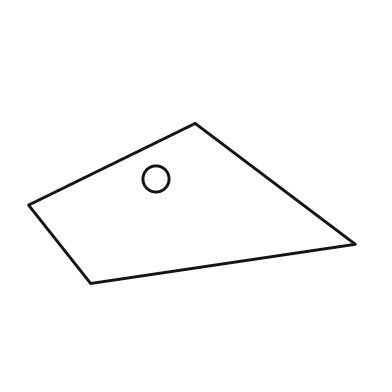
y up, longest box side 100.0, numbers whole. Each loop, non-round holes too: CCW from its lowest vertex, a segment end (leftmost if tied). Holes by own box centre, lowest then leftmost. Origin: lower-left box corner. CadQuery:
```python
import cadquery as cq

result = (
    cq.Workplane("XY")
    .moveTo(19.0, 0.0)
    .lineTo(100.0, 12.0)
    .lineTo(51.0, 49.0)
    .lineTo(0.0, 24.0)
    .close()
    .moveTo(39.0, 32.0)
    .circle(4.0)
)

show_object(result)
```